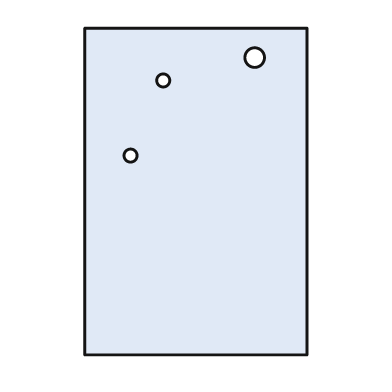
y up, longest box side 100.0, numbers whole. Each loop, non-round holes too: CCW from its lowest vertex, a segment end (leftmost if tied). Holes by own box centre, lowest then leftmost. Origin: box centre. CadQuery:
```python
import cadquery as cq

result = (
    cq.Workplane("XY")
    .moveTo(-34.0, -50.0)
    .lineTo(34.0, -50.0)
    .lineTo(34.0, 50.0)
    .lineTo(-34.0, 50.0)
    .close()
    .moveTo(-20.0, 11.0)
    .circle(2.0)
    .moveTo(-10.0, 34.0)
    .circle(2.0)
    .moveTo(18.0, 41.0)
    .circle(3.0)
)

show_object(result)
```